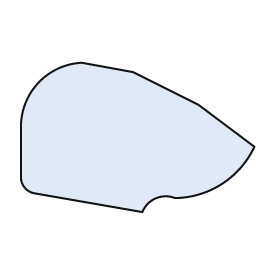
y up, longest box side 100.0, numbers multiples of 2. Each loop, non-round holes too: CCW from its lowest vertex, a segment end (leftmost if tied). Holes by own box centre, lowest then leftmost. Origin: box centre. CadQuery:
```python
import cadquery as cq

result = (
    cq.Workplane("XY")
    .moveTo(2.0, -32.0)
    .threePointArc((8.0, -26.0), (16.0, -26.0))
    .threePointArc((36.0, -20.0), (50.0, -4.0))
    .lineTo(26.0, 14.0)
    .lineTo(-2.0, 28.0)
    .lineTo(-24.0, 32.0)
    .threePointArc((-42.0, 24.0), (-50.0, 6.0))
    .lineTo(-50.0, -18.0)
    .threePointArc((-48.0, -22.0), (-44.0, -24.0))
    .close()
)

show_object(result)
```